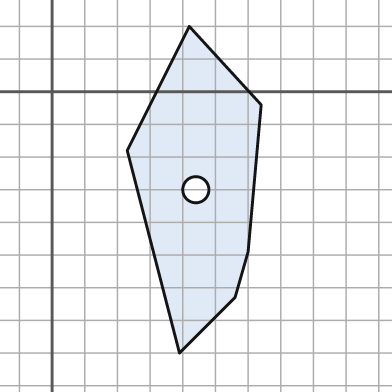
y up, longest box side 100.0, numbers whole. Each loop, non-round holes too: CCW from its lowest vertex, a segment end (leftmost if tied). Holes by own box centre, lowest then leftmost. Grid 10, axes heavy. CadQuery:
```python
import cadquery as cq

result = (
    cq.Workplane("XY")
    .moveTo(39.0, -80.0)
    .lineTo(56.0, -63.0)
    .lineTo(60.0, -49.0)
    .lineTo(64.0, -4.0)
    .lineTo(42.0, 20.0)
    .lineTo(23.0, -18.0)
    .close()
    .moveTo(44.0, -30.0)
    .circle(4.0)
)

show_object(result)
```